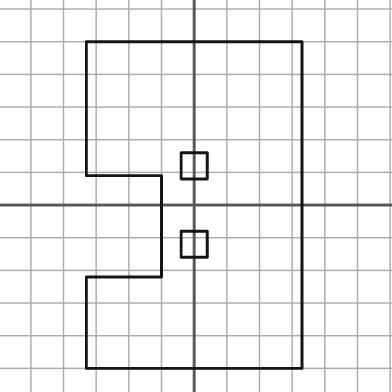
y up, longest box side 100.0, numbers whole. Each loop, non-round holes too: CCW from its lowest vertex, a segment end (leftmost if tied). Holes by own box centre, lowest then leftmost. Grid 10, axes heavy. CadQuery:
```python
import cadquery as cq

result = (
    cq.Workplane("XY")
    .moveTo(-33.0, -50.0)
    .lineTo(33.0, -50.0)
    .lineTo(33.0, 50.0)
    .lineTo(-33.0, 50.0)
    .lineTo(-33.0, 9.0)
    .lineTo(-10.0, 9.0)
    .lineTo(-10.0, -22.0)
    .lineTo(-33.0, -22.0)
    .close()
    .moveTo(-4.0, -16.0)
    .lineTo(4.0, -16.0)
    .lineTo(4.0, -8.0)
    .lineTo(-4.0, -8.0)
    .close()
    .moveTo(-4.0, 8.0)
    .lineTo(4.0, 8.0)
    .lineTo(4.0, 16.0)
    .lineTo(-4.0, 16.0)
    .close()
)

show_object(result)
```